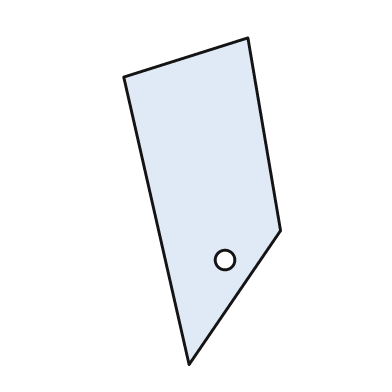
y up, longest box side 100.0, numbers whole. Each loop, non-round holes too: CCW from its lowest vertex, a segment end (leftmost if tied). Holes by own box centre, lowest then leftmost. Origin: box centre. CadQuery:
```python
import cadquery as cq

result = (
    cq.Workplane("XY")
    .moveTo(-4.0, -50.0)
    .lineTo(24.0, -9.0)
    .lineTo(14.0, 50.0)
    .lineTo(-24.0, 38.0)
    .close()
    .moveTo(7.0, -18.0)
    .circle(3.0)
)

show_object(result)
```